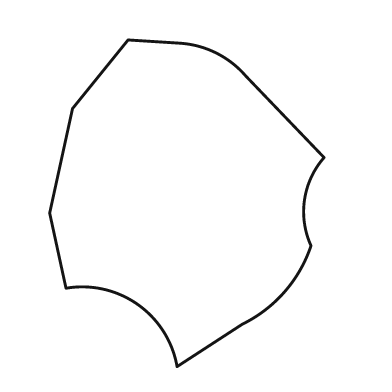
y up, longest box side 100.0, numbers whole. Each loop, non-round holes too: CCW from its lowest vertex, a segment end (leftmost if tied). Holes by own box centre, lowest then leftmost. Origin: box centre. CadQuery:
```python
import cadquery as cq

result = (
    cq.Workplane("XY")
    .moveTo(-3.0, -50.0)
    .lineTo(17.0, -37.0)
    .threePointArc((30.0, -27.0), (38.0, -13.0))
    .threePointArc((36.0, 1.0), (42.0, 14.0))
    .lineTo(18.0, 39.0)
    .threePointArc((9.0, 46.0), (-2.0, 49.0))
    .lineTo(-18.0, 50.0)
    .lineTo(-35.0, 29.0)
    .lineTo(-42.0, -3.0)
    .lineTo(-37.0, -26.0)
    .threePointArc((-15.0, -31.0), (-3.0, -50.0))
    .close()
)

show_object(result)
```